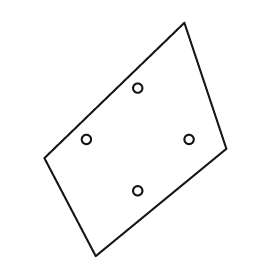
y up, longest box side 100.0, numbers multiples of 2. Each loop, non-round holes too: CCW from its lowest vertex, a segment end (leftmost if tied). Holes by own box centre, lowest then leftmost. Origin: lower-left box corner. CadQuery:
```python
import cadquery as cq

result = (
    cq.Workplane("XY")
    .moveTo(22.0, 0.0)
    .lineTo(78.0, 46.0)
    .lineTo(60.0, 100.0)
    .lineTo(0.0, 42.0)
    .close()
    .moveTo(40.0, 28.0)
    .circle(2.0)
    .moveTo(18.0, 50.0)
    .circle(2.0)
    .moveTo(62.0, 50.0)
    .circle(2.0)
    .moveTo(40.0, 72.0)
    .circle(2.0)
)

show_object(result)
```